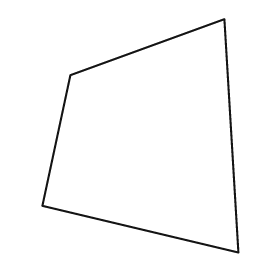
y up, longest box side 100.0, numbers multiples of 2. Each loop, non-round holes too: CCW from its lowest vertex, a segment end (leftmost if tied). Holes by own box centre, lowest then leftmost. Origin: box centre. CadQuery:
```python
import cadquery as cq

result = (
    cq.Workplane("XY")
    .moveTo(42.0, -50.0)
    .lineTo(36.0, 50.0)
    .lineTo(-30.0, 26.0)
    .lineTo(-42.0, -30.0)
    .close()
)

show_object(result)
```